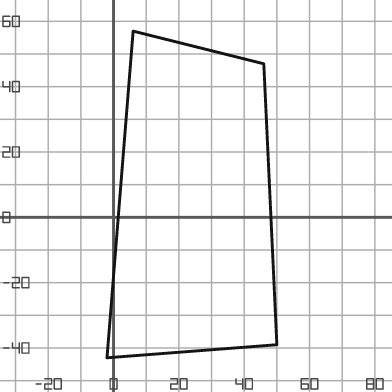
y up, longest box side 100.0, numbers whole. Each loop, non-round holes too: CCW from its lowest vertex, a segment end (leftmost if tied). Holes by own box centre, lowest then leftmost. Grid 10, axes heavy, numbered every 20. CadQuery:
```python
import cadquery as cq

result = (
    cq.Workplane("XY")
    .moveTo(-2.0, -43.0)
    .lineTo(50.0, -39.0)
    .lineTo(46.0, 47.0)
    .lineTo(6.0, 57.0)
    .close()
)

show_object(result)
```